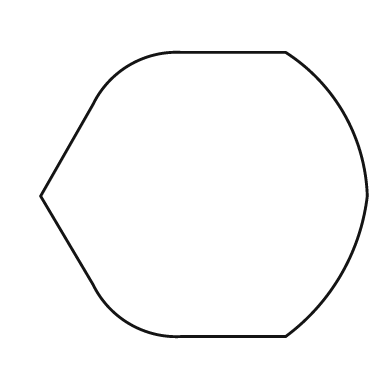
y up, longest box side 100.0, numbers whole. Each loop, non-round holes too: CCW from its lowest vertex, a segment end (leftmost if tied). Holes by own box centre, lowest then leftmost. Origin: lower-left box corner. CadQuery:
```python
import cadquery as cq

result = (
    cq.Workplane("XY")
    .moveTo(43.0, 0.0)
    .lineTo(75.0, 0.0)
    .threePointArc((92.0, 19.0), (100.0, 43.0))
    .threePointArc((93.0, 68.0), (75.0, 87.0))
    .lineTo(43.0, 87.0)
    .threePointArc((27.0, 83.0), (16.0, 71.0))
    .lineTo(0.0, 43.0)
    .lineTo(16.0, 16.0)
    .threePointArc((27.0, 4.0), (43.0, 0.0))
    .close()
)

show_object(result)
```